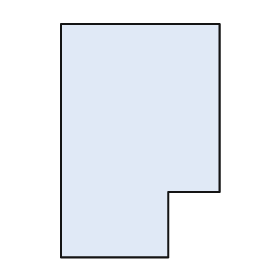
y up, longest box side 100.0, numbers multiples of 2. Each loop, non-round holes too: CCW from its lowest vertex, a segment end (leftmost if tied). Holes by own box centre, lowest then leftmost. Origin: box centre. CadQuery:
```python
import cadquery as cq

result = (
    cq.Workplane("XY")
    .moveTo(-34.0, -50.0)
    .lineTo(12.0, -50.0)
    .lineTo(12.0, -22.0)
    .lineTo(34.0, -22.0)
    .lineTo(34.0, 50.0)
    .lineTo(-34.0, 50.0)
    .close()
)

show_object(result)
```